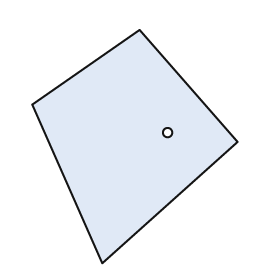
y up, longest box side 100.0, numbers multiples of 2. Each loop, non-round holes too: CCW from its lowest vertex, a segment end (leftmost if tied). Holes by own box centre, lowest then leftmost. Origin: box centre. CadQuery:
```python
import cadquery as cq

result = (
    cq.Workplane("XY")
    .moveTo(-14.0, -50.0)
    .lineTo(44.0, 2.0)
    .lineTo(2.0, 50.0)
    .lineTo(-44.0, 18.0)
    .close()
    .moveTo(14.0, 6.0)
    .circle(2.0)
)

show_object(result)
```